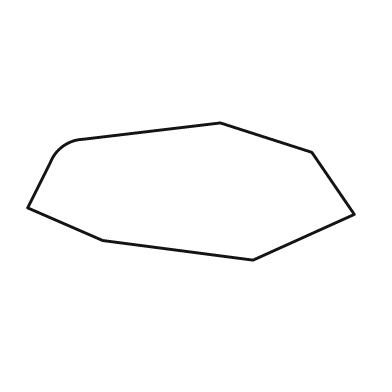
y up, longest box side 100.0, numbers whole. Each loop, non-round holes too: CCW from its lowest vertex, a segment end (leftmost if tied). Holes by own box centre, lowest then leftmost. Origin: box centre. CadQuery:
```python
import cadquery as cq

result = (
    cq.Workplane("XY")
    .moveTo(19.0, -21.0)
    .lineTo(50.0, -7.0)
    .lineTo(37.0, 12.0)
    .lineTo(9.0, 21.0)
    .lineTo(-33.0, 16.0)
    .threePointArc((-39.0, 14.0), (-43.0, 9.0))
    .lineTo(-50.0, -5.0)
    .lineTo(-27.0, -15.0)
    .close()
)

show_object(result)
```